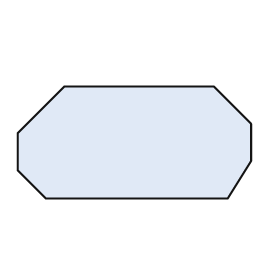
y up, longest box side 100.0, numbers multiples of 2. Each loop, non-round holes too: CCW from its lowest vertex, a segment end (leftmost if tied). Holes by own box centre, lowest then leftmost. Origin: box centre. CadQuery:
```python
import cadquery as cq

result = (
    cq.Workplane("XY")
    .moveTo(-38.0, -24.0)
    .lineTo(40.0, -24.0)
    .lineTo(50.0, -8.0)
    .lineTo(50.0, 8.0)
    .lineTo(34.0, 24.0)
    .lineTo(-30.0, 24.0)
    .lineTo(-50.0, 4.0)
    .lineTo(-50.0, -12.0)
    .close()
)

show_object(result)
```